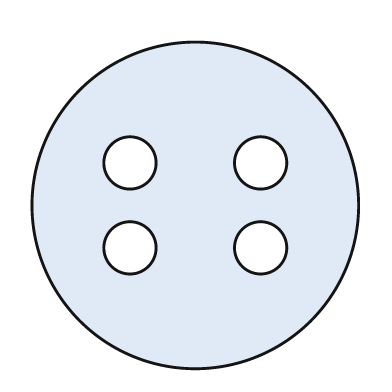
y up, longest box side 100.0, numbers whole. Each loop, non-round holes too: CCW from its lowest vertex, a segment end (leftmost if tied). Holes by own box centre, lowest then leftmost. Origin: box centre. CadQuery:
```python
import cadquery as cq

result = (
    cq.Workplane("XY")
    .moveTo(0.0, 0.0)
    .circle(50.0)
    .moveTo(-20.0, -13.0)
    .circle(8.0)
    .moveTo(20.0, -13.0)
    .circle(8.0)
    .moveTo(-20.0, 13.0)
    .circle(8.0)
    .moveTo(20.0, 13.0)
    .circle(8.0)
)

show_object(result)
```